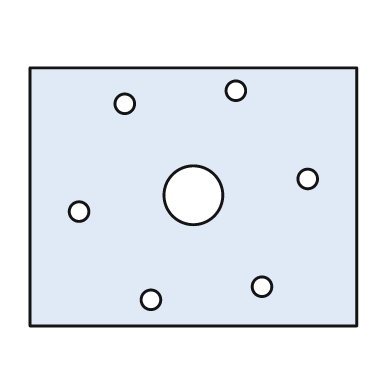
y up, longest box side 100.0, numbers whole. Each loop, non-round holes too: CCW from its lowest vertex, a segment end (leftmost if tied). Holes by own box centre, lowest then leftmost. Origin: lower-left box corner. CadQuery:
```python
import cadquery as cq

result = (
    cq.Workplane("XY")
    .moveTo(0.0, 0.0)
    .lineTo(100.0, 0.0)
    .lineTo(100.0, 79.0)
    .lineTo(0.0, 79.0)
    .close()
    .moveTo(37.0, 8.0)
    .circle(3.0)
    .moveTo(71.0, 12.0)
    .circle(3.0)
    .moveTo(15.0, 35.0)
    .circle(3.0)
    .moveTo(50.0, 40.0)
    .circle(9.0)
    .moveTo(85.0, 45.0)
    .circle(3.0)
    .moveTo(29.0, 68.0)
    .circle(3.0)
    .moveTo(63.0, 72.0)
    .circle(3.0)
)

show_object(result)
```